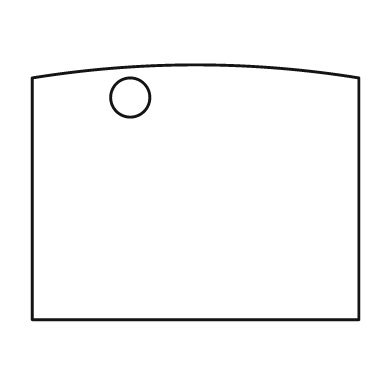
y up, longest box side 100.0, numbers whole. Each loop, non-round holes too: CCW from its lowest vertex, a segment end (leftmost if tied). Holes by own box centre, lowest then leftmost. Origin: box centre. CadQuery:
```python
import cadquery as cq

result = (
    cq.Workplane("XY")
    .moveTo(-50.0, -39.0)
    .lineTo(50.0, -39.0)
    .lineTo(50.0, 35.0)
    .threePointArc((0.0, 39.0), (-50.0, 35.0))
    .close()
    .moveTo(-20.0, 29.0)
    .circle(6.0)
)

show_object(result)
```